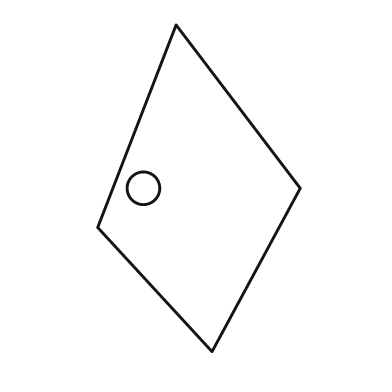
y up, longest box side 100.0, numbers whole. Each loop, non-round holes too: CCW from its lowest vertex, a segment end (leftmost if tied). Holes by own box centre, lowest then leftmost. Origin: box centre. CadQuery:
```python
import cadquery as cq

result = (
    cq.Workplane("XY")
    .moveTo(4.0, -50.0)
    .lineTo(31.0, 0.0)
    .lineTo(-7.0, 50.0)
    .lineTo(-31.0, -12.0)
    .close()
    .moveTo(-17.0, 0.0)
    .circle(5.0)
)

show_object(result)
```